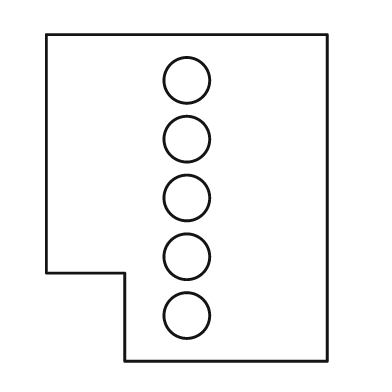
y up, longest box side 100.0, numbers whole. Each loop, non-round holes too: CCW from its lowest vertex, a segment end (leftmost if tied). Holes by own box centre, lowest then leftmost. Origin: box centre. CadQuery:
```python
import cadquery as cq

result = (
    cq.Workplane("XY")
    .moveTo(-19.0, -50.0)
    .lineTo(43.0, -50.0)
    .lineTo(43.0, 50.0)
    .lineTo(-43.0, 50.0)
    .lineTo(-43.0, -23.0)
    .lineTo(-19.0, -23.0)
    .close()
    .moveTo(0.0, -36.0)
    .circle(7.0)
    .moveTo(0.0, -18.0)
    .circle(7.0)
    .moveTo(0.0, 0.0)
    .circle(7.0)
    .moveTo(0.0, 18.0)
    .circle(7.0)
    .moveTo(0.0, 36.0)
    .circle(7.0)
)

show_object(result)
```